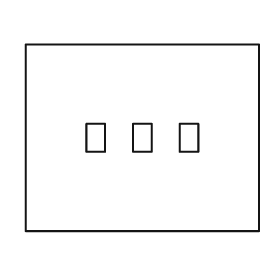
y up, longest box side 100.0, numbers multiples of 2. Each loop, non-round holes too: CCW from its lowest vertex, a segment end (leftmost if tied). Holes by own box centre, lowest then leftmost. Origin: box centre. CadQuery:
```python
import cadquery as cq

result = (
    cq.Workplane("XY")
    .moveTo(-50.0, -40.0)
    .lineTo(50.0, -40.0)
    .lineTo(50.0, 40.0)
    .lineTo(-50.0, 40.0)
    .close()
    .moveTo(-24.0, -6.0)
    .lineTo(-16.0, -6.0)
    .lineTo(-16.0, 6.0)
    .lineTo(-24.0, 6.0)
    .close()
    .moveTo(-4.0, -6.0)
    .lineTo(4.0, -6.0)
    .lineTo(4.0, 6.0)
    .lineTo(-4.0, 6.0)
    .close()
    .moveTo(16.0, -6.0)
    .lineTo(24.0, -6.0)
    .lineTo(24.0, 6.0)
    .lineTo(16.0, 6.0)
    .close()
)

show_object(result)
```